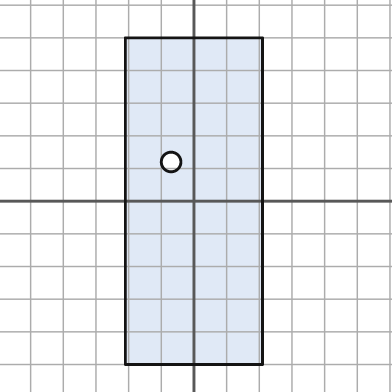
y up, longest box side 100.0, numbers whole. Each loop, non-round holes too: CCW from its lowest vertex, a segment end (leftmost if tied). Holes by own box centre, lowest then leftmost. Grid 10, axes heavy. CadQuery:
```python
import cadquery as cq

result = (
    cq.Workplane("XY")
    .moveTo(-21.0, -50.0)
    .lineTo(21.0, -50.0)
    .lineTo(21.0, 50.0)
    .lineTo(-21.0, 50.0)
    .close()
    .moveTo(-7.0, 12.0)
    .circle(3.0)
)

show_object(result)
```